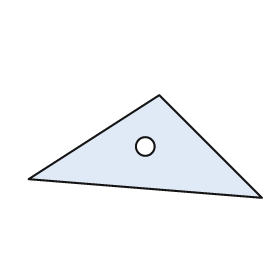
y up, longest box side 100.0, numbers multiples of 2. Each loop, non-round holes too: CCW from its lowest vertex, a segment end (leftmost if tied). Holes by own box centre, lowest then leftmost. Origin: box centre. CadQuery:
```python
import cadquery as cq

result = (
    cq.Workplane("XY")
    .moveTo(50.0, -22.0)
    .lineTo(6.0, 22.0)
    .lineTo(-50.0, -14.0)
    .close()
    .moveTo(0.0, 0.0)
    .circle(4.0)
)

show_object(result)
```